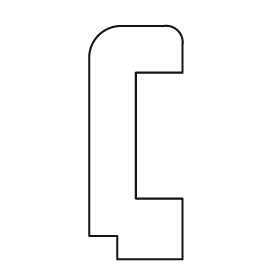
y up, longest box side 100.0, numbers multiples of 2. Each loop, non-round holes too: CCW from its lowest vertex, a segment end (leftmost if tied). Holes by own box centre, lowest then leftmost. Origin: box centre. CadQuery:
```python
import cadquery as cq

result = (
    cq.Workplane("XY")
    .moveTo(-8.0, -50.0)
    .lineTo(20.0, -50.0)
    .lineTo(20.0, -24.0)
    .lineTo(0.0, -24.0)
    .lineTo(0.0, 30.0)
    .lineTo(20.0, 30.0)
    .lineTo(20.0, 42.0)
    .threePointArc((18.0, 48.0), (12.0, 50.0))
    .lineTo(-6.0, 50.0)
    .threePointArc((-16.0, 46.0), (-20.0, 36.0))
    .lineTo(-20.0, -40.0)
    .lineTo(-8.0, -40.0)
    .close()
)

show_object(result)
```